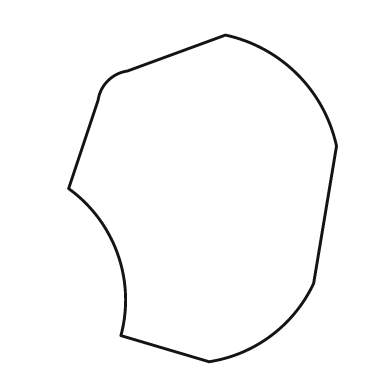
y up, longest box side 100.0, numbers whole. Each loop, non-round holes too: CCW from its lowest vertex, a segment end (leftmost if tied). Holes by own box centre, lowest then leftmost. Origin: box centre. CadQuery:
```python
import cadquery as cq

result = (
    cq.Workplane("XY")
    .moveTo(2.0, -50.0)
    .threePointArc((21.0, -42.0), (34.0, -26.0))
    .lineTo(41.0, 16.0)
    .threePointArc((29.0, 38.0), (7.0, 50.0))
    .lineTo(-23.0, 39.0)
    .threePointArc((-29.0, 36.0), (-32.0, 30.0))
    .lineTo(-41.0, 3.0)
    .threePointArc((-26.0, -17.0), (-25.0, -42.0))
    .close()
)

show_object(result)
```